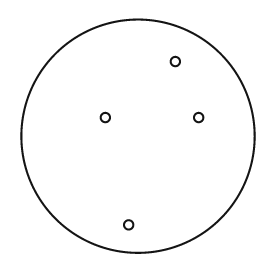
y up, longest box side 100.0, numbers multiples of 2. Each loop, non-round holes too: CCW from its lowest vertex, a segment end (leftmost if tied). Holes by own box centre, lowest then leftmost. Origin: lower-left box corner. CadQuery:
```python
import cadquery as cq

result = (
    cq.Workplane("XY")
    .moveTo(50.0, 50.0)
    .circle(50.0)
    .moveTo(46.0, 12.0)
    .circle(2.0)
    .moveTo(36.0, 58.0)
    .circle(2.0)
    .moveTo(76.0, 58.0)
    .circle(2.0)
    .moveTo(66.0, 82.0)
    .circle(2.0)
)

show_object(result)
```